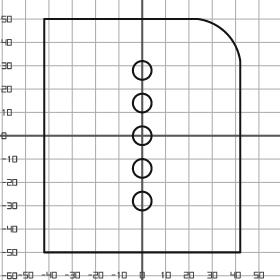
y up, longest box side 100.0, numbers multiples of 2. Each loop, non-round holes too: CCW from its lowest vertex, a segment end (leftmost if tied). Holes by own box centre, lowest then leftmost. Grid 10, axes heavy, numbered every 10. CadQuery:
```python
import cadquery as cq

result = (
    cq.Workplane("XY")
    .moveTo(-42.0, -50.0)
    .lineTo(42.0, -50.0)
    .lineTo(42.0, 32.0)
    .threePointArc((36.0, 44.0), (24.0, 50.0))
    .lineTo(-42.0, 50.0)
    .close()
    .moveTo(0.0, -28.0)
    .circle(4.0)
    .moveTo(0.0, -14.0)
    .circle(4.0)
    .moveTo(0.0, 0.0)
    .circle(4.0)
    .moveTo(0.0, 14.0)
    .circle(4.0)
    .moveTo(0.0, 28.0)
    .circle(4.0)
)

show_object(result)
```